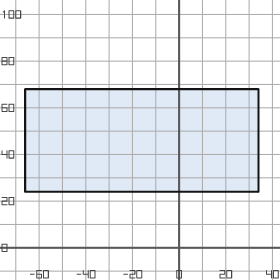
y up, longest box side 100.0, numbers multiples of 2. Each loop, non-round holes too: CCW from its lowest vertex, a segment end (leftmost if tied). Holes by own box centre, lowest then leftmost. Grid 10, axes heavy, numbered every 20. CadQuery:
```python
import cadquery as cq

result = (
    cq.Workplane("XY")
    .moveTo(-66.0, 24.0)
    .lineTo(34.0, 24.0)
    .lineTo(34.0, 68.0)
    .lineTo(-66.0, 68.0)
    .close()
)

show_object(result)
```